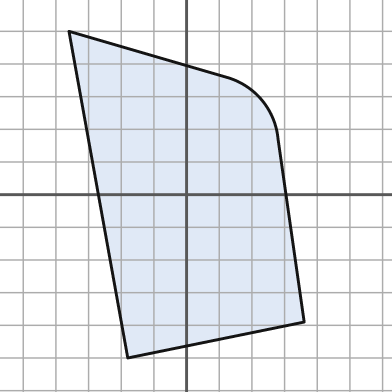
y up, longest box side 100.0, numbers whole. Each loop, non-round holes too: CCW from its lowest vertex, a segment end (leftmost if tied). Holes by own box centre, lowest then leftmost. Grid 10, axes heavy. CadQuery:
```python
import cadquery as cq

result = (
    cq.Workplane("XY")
    .moveTo(-18.0, -50.0)
    .lineTo(36.0, -39.0)
    .lineTo(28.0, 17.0)
    .threePointArc((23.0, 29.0), (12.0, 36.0))
    .lineTo(-36.0, 50.0)
    .close()
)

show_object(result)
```